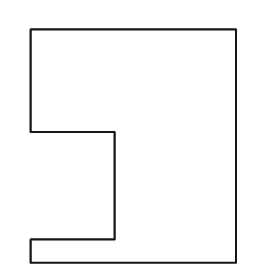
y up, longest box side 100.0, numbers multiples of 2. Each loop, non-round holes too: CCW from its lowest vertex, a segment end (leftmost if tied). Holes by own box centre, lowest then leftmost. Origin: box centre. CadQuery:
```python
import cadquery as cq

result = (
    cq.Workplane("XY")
    .moveTo(-44.0, -50.0)
    .lineTo(44.0, -50.0)
    .lineTo(44.0, 50.0)
    .lineTo(-44.0, 50.0)
    .lineTo(-44.0, 6.0)
    .lineTo(-8.0, 6.0)
    .lineTo(-8.0, -40.0)
    .lineTo(-44.0, -40.0)
    .close()
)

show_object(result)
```